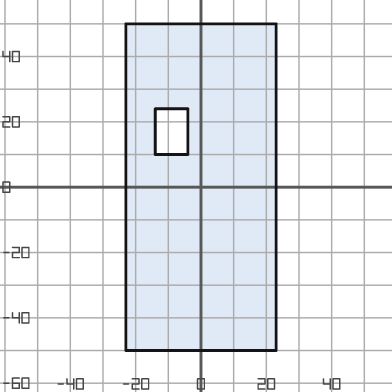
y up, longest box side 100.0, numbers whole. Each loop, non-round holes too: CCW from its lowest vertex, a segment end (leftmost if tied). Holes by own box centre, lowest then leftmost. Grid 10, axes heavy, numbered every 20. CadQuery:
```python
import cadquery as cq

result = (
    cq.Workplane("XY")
    .moveTo(-23.0, -50.0)
    .lineTo(23.0, -50.0)
    .lineTo(23.0, 50.0)
    .lineTo(-23.0, 50.0)
    .close()
    .moveTo(-14.0, 10.0)
    .lineTo(-4.0, 10.0)
    .lineTo(-4.0, 24.0)
    .lineTo(-14.0, 24.0)
    .close()
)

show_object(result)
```